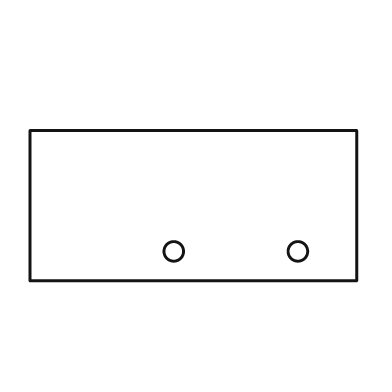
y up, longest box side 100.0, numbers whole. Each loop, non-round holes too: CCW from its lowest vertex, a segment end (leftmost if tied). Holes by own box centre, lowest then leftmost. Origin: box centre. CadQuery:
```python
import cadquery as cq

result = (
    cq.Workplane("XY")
    .moveTo(-50.0, -23.0)
    .lineTo(50.0, -23.0)
    .lineTo(50.0, 23.0)
    .lineTo(-50.0, 23.0)
    .close()
    .moveTo(-6.0, -14.0)
    .circle(3.0)
    .moveTo(32.0, -14.0)
    .circle(3.0)
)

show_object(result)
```